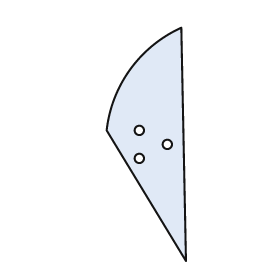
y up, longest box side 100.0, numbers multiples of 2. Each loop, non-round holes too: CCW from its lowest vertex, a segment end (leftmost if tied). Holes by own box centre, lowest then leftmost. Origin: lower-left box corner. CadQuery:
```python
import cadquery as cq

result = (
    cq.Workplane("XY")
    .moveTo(34.0, 0.0)
    .lineTo(32.0, 100.0)
    .threePointArc((10.0, 82.0), (0.0, 56.0))
    .close()
    .moveTo(14.0, 44.0)
    .circle(2.0)
    .moveTo(26.0, 50.0)
    .circle(2.0)
    .moveTo(14.0, 56.0)
    .circle(2.0)
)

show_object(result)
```